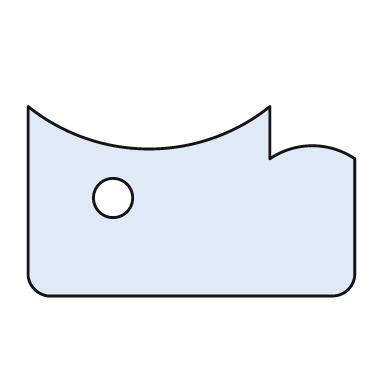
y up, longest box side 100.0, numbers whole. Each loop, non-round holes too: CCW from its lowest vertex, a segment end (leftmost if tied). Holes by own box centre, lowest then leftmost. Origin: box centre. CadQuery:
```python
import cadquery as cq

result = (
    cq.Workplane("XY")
    .moveTo(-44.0, -29.0)
    .lineTo(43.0, -29.0)
    .threePointArc((48.0, -27.0), (50.0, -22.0))
    .lineTo(50.0, 13.0)
    .threePointArc((37.0, 17.0), (24.0, 13.0))
    .lineTo(24.0, 29.0)
    .threePointArc((-13.0, 16.0), (-50.0, 29.0))
    .lineTo(-50.0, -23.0)
    .threePointArc((-48.0, -27.0), (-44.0, -29.0))
    .close()
    .moveTo(-24.0, 1.0)
    .circle(6.0)
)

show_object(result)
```